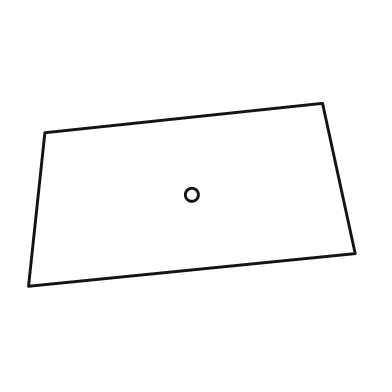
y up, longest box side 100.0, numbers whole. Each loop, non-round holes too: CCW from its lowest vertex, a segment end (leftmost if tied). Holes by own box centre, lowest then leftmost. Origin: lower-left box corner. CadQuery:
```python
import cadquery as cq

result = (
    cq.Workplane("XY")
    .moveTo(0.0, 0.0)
    .lineTo(100.0, 10.0)
    .lineTo(90.0, 56.0)
    .lineTo(5.0, 47.0)
    .close()
    .moveTo(50.0, 28.0)
    .circle(2.0)
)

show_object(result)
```